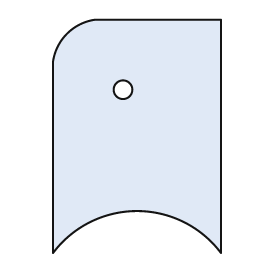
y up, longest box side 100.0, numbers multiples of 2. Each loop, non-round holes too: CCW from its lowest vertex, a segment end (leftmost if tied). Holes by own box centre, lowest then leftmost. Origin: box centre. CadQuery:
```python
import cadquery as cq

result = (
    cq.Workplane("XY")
    .moveTo(-36.0, -50.0)
    .threePointArc((0.0, -32.0), (36.0, -50.0))
    .lineTo(36.0, 50.0)
    .lineTo(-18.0, 50.0)
    .threePointArc((-30.0, 44.0), (-36.0, 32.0))
    .close()
    .moveTo(-6.0, 20.0)
    .circle(4.0)
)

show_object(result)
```